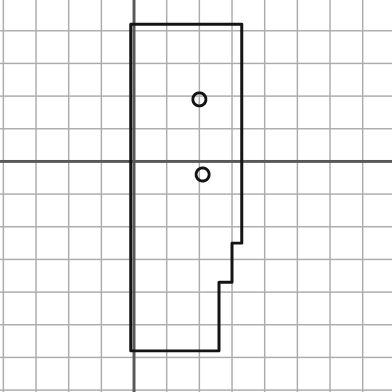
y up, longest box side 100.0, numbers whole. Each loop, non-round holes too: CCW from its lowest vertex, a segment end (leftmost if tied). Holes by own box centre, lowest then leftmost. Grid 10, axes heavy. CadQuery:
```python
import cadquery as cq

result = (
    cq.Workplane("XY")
    .moveTo(-1.0, -58.0)
    .lineTo(26.0, -58.0)
    .lineTo(26.0, -37.0)
    .lineTo(30.0, -37.0)
    .lineTo(30.0, -25.0)
    .lineTo(33.0, -25.0)
    .lineTo(33.0, 42.0)
    .lineTo(-1.0, 42.0)
    .close()
    .moveTo(21.0, -4.0)
    .circle(2.0)
    .moveTo(20.0, 19.0)
    .circle(2.0)
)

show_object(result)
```